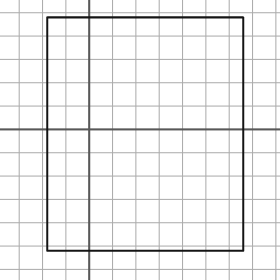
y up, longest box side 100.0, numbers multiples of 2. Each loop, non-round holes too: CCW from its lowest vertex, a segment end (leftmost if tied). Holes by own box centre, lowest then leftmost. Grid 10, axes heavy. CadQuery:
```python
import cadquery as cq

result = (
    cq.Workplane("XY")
    .moveTo(-18.0, -52.0)
    .lineTo(66.0, -52.0)
    .lineTo(66.0, 48.0)
    .lineTo(-18.0, 48.0)
    .close()
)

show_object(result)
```